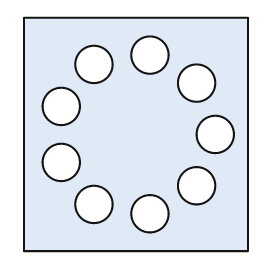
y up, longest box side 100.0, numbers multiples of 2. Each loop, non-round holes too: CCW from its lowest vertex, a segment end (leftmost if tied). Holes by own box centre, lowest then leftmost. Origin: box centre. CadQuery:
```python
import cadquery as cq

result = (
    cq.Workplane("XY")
    .moveTo(-48.0, -50.0)
    .lineTo(48.0, -50.0)
    .lineTo(48.0, 50.0)
    .lineTo(-48.0, 50.0)
    .close()
    .moveTo(6.0, -34.0)
    .circle(8.0)
    .moveTo(-18.0, -30.0)
    .circle(8.0)
    .moveTo(26.0, -22.0)
    .circle(8.0)
    .moveTo(-32.0, -12.0)
    .circle(8.0)
    .moveTo(34.0, 0.0)
    .circle(8.0)
    .moveTo(-32.0, 12.0)
    .circle(8.0)
    .moveTo(26.0, 22.0)
    .circle(8.0)
    .moveTo(-18.0, 30.0)
    .circle(8.0)
    .moveTo(6.0, 34.0)
    .circle(8.0)
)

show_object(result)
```